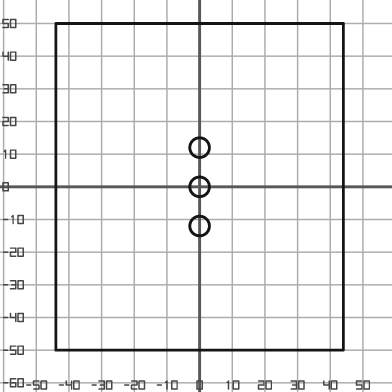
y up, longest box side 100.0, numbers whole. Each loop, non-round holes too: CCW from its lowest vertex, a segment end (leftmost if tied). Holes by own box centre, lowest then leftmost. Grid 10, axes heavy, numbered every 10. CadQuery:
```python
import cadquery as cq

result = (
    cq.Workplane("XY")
    .moveTo(-44.0, -50.0)
    .lineTo(44.0, -50.0)
    .lineTo(44.0, 50.0)
    .lineTo(-44.0, 50.0)
    .close()
    .moveTo(0.0, -12.0)
    .circle(3.0)
    .moveTo(0.0, 0.0)
    .circle(3.0)
    .moveTo(0.0, 12.0)
    .circle(3.0)
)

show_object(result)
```